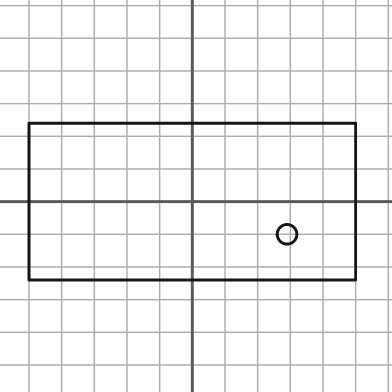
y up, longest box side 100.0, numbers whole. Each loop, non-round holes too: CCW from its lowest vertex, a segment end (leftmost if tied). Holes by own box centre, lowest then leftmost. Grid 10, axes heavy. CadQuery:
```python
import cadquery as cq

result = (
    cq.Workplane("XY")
    .moveTo(-50.0, -24.0)
    .lineTo(50.0, -24.0)
    .lineTo(50.0, 24.0)
    .lineTo(-50.0, 24.0)
    .close()
    .moveTo(29.0, -10.0)
    .circle(3.0)
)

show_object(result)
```